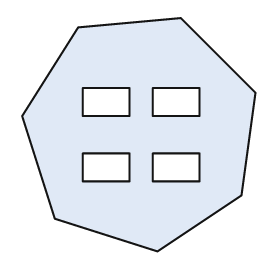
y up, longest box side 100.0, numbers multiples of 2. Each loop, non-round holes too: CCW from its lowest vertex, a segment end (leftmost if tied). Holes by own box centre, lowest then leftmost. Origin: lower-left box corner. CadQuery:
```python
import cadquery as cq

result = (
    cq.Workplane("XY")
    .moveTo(58.0, 0.0)
    .lineTo(94.0, 24.0)
    .lineTo(100.0, 68.0)
    .lineTo(68.0, 100.0)
    .lineTo(24.0, 96.0)
    .lineTo(0.0, 58.0)
    .lineTo(14.0, 14.0)
    .close()
    .moveTo(26.0, 30.0)
    .lineTo(46.0, 30.0)
    .lineTo(46.0, 42.0)
    .lineTo(26.0, 42.0)
    .close()
    .moveTo(56.0, 30.0)
    .lineTo(76.0, 30.0)
    .lineTo(76.0, 42.0)
    .lineTo(56.0, 42.0)
    .close()
    .moveTo(26.0, 58.0)
    .lineTo(46.0, 58.0)
    .lineTo(46.0, 70.0)
    .lineTo(26.0, 70.0)
    .close()
    .moveTo(56.0, 58.0)
    .lineTo(76.0, 58.0)
    .lineTo(76.0, 70.0)
    .lineTo(56.0, 70.0)
    .close()
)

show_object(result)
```